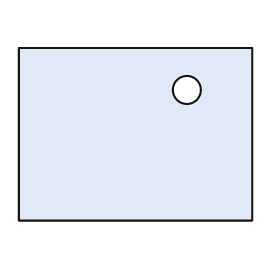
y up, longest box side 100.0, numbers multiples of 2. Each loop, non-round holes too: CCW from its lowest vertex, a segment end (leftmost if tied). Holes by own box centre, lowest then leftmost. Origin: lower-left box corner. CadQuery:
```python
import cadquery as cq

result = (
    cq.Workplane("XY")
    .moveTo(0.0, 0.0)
    .lineTo(100.0, 0.0)
    .lineTo(100.0, 74.0)
    .lineTo(0.0, 74.0)
    .close()
    .moveTo(72.0, 56.0)
    .circle(6.0)
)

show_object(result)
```